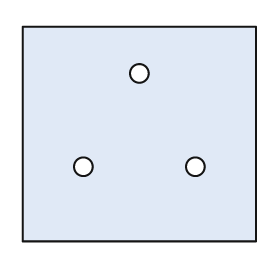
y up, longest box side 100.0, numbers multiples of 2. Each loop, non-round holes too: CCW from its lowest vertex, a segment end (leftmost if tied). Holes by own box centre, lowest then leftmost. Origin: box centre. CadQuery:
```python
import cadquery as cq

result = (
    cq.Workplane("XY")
    .moveTo(-50.0, -46.0)
    .lineTo(50.0, -46.0)
    .lineTo(50.0, 46.0)
    .lineTo(-50.0, 46.0)
    .close()
    .moveTo(-24.0, -14.0)
    .circle(4.0)
    .moveTo(24.0, -14.0)
    .circle(4.0)
    .moveTo(0.0, 26.0)
    .circle(4.0)
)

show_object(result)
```